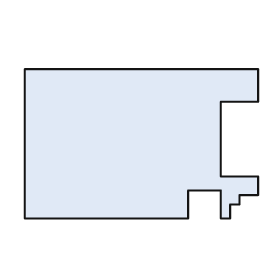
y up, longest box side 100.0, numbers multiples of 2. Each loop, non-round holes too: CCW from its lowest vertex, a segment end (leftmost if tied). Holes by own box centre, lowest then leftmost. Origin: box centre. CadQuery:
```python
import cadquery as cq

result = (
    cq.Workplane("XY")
    .moveTo(-50.0, -32.0)
    .lineTo(20.0, -32.0)
    .lineTo(20.0, -20.0)
    .lineTo(34.0, -20.0)
    .lineTo(34.0, -32.0)
    .lineTo(38.0, -32.0)
    .lineTo(38.0, -26.0)
    .lineTo(42.0, -26.0)
    .lineTo(42.0, -22.0)
    .lineTo(50.0, -22.0)
    .lineTo(50.0, -14.0)
    .lineTo(34.0, -14.0)
    .lineTo(34.0, 18.0)
    .lineTo(50.0, 18.0)
    .lineTo(50.0, 32.0)
    .lineTo(-50.0, 32.0)
    .close()
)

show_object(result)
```